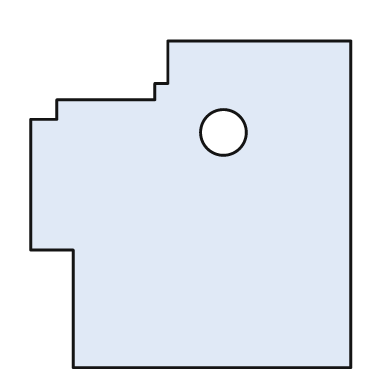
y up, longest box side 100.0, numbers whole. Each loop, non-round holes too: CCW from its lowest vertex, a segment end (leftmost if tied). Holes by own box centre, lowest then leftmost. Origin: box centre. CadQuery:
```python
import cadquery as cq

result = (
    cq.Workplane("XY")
    .moveTo(-36.0, -50.0)
    .lineTo(49.0, -50.0)
    .lineTo(49.0, 50.0)
    .lineTo(-7.0, 50.0)
    .lineTo(-7.0, 37.0)
    .lineTo(-11.0, 37.0)
    .lineTo(-11.0, 32.0)
    .lineTo(-41.0, 32.0)
    .lineTo(-41.0, 26.0)
    .lineTo(-49.0, 26.0)
    .lineTo(-49.0, -14.0)
    .lineTo(-36.0, -14.0)
    .close()
    .moveTo(10.0, 22.0)
    .circle(7.0)
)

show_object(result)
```